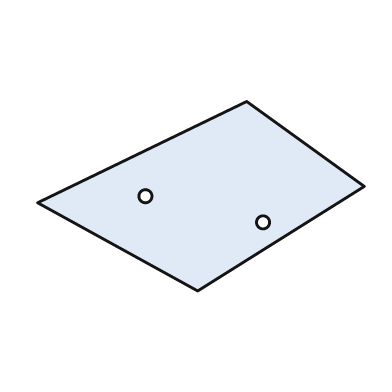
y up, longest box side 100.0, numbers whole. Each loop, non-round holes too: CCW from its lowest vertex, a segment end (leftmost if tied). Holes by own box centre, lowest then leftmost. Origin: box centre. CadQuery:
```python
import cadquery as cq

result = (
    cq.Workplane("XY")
    .moveTo(-1.0, -29.0)
    .lineTo(50.0, 3.0)
    .lineTo(14.0, 29.0)
    .lineTo(-50.0, -2.0)
    .close()
    .moveTo(19.0, -8.0)
    .circle(2.0)
    .moveTo(-17.0, 0.0)
    .circle(2.0)
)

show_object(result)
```